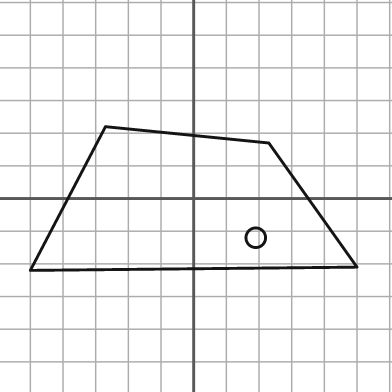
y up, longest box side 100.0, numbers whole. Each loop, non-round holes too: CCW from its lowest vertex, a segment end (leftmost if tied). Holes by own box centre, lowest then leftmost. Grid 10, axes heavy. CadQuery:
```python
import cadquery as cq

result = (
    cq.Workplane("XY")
    .moveTo(-50.0, -22.0)
    .lineTo(50.0, -21.0)
    .lineTo(23.0, 17.0)
    .lineTo(-27.0, 22.0)
    .close()
    .moveTo(19.0, -12.0)
    .circle(3.0)
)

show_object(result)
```